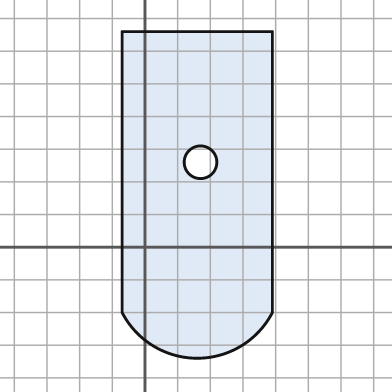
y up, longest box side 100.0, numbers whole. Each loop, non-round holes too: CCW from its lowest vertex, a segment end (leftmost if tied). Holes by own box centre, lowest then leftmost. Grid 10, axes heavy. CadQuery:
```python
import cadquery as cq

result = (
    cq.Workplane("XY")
    .moveTo(-7.0, -20.0)
    .threePointArc((16.0, -34.0), (39.0, -20.0))
    .lineTo(39.0, 66.0)
    .lineTo(-7.0, 66.0)
    .close()
    .moveTo(17.0, 26.0)
    .circle(5.0)
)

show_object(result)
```